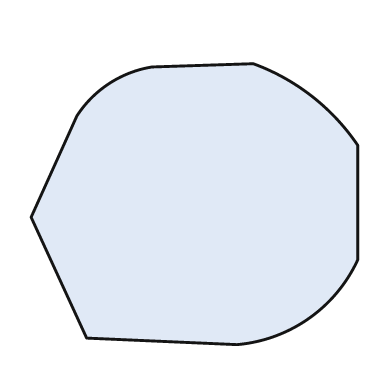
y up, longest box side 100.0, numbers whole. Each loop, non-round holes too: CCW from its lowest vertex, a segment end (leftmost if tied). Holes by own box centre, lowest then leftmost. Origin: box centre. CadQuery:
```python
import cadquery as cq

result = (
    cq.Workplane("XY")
    .moveTo(13.0, -43.0)
    .threePointArc((35.0, -35.0), (50.0, -17.0))
    .lineTo(50.0, 18.0)
    .threePointArc((36.0, 33.0), (18.0, 43.0))
    .lineTo(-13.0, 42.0)
    .threePointArc((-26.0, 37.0), (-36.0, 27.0))
    .lineTo(-50.0, -4.0)
    .lineTo(-33.0, -41.0)
    .close()
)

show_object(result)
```